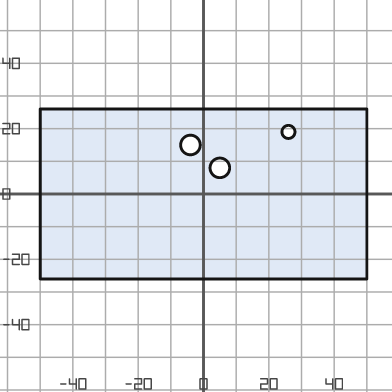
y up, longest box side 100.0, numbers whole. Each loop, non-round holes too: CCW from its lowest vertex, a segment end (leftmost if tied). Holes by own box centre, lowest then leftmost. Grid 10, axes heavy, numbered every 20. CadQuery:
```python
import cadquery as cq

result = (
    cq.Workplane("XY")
    .moveTo(-50.0, -26.0)
    .lineTo(50.0, -26.0)
    .lineTo(50.0, 26.0)
    .lineTo(-50.0, 26.0)
    .close()
    .moveTo(5.0, 8.0)
    .circle(3.0)
    .moveTo(-4.0, 15.0)
    .circle(3.0)
    .moveTo(26.0, 19.0)
    .circle(2.0)
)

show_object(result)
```